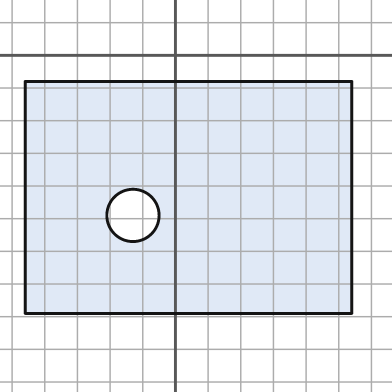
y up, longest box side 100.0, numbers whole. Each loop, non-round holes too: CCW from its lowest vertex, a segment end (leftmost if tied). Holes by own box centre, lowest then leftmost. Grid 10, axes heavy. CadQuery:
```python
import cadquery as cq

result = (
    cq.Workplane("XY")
    .moveTo(-46.0, -79.0)
    .lineTo(54.0, -79.0)
    .lineTo(54.0, -8.0)
    .lineTo(-46.0, -8.0)
    .close()
    .moveTo(-13.0, -49.0)
    .circle(8.0)
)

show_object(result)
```